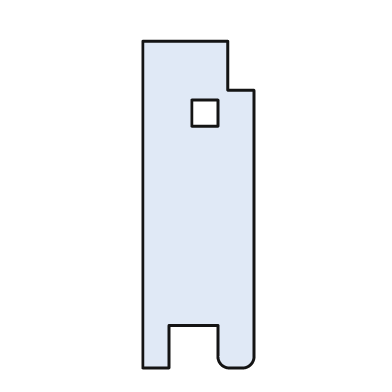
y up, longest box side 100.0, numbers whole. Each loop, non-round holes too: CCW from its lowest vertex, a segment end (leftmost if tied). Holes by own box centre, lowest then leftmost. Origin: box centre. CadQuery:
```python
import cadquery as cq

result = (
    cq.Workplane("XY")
    .moveTo(-17.0, -50.0)
    .lineTo(-9.0, -50.0)
    .lineTo(-9.0, -37.0)
    .lineTo(6.0, -37.0)
    .lineTo(6.0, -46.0)
    .threePointArc((7.0, -49.0), (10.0, -50.0))
    .lineTo(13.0, -50.0)
    .threePointArc((16.0, -49.0), (17.0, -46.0))
    .lineTo(17.0, 35.0)
    .lineTo(9.0, 35.0)
    .lineTo(9.0, 50.0)
    .lineTo(-17.0, 50.0)
    .close()
    .moveTo(-2.0, 24.0)
    .lineTo(6.0, 24.0)
    .lineTo(6.0, 32.0)
    .lineTo(-2.0, 32.0)
    .close()
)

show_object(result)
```